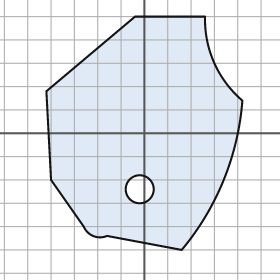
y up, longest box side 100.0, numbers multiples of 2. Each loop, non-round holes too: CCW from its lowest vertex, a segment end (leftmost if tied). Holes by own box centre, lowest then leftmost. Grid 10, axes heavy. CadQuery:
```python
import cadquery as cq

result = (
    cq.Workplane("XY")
    .moveTo(16.0, -50.0)
    .threePointArc((34.0, -20.0), (42.0, 14.0))
    .threePointArc((30.0, 30.0), (26.0, 50.0))
    .lineTo(-4.0, 50.0)
    .lineTo(-42.0, 18.0)
    .lineTo(-40.0, -20.0)
    .lineTo(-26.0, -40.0)
    .threePointArc((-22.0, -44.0), (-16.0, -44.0))
    .close()
    .moveTo(-2.0, -24.0)
    .circle(6.0)
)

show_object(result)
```